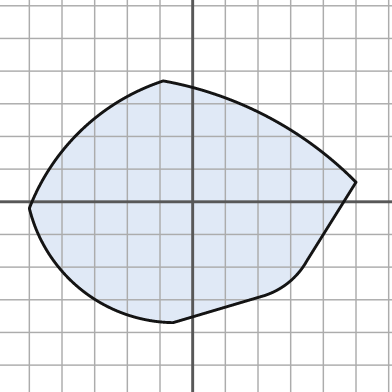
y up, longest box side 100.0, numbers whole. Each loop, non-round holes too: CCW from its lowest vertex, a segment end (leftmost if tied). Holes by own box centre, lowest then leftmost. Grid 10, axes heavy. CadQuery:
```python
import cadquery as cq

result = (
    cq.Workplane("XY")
    .moveTo(-6.0, -37.0)
    .lineTo(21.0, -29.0)
    .threePointArc((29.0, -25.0), (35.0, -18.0))
    .lineTo(50.0, 6.0)
    .threePointArc((23.0, 26.0), (-9.0, 37.0))
    .threePointArc((-34.0, 22.0), (-50.0, -2.0))
    .threePointArc((-34.0, -27.0), (-6.0, -37.0))
    .close()
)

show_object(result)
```